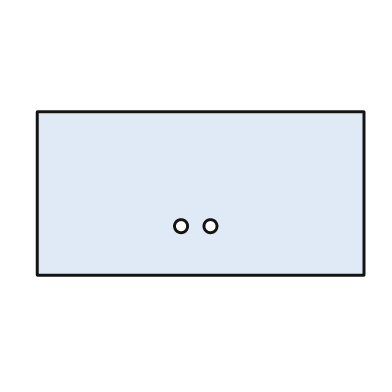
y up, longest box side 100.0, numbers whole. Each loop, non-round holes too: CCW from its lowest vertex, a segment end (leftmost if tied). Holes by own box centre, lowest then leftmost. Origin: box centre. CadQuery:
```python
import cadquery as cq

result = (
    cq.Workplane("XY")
    .moveTo(-50.0, -25.0)
    .lineTo(50.0, -25.0)
    .lineTo(50.0, 25.0)
    .lineTo(-50.0, 25.0)
    .close()
    .moveTo(-6.0, -10.0)
    .circle(2.0)
    .moveTo(3.0, -10.0)
    .circle(2.0)
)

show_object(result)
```